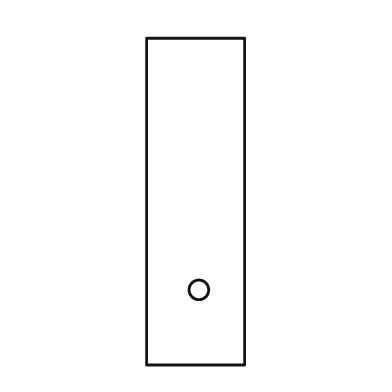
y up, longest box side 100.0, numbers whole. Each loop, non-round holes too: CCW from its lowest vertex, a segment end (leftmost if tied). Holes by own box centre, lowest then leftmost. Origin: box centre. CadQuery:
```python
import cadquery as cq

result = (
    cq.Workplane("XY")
    .moveTo(-15.0, -50.0)
    .lineTo(15.0, -50.0)
    .lineTo(15.0, 50.0)
    .lineTo(-15.0, 50.0)
    .close()
    .moveTo(1.0, -27.0)
    .circle(3.0)
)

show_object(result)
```